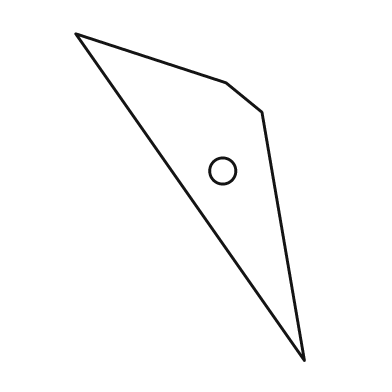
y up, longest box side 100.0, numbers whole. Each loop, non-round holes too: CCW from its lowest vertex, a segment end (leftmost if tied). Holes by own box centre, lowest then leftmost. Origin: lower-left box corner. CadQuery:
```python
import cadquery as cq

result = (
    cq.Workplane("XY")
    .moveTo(70.0, 0.0)
    .lineTo(57.0, 76.0)
    .lineTo(46.0, 85.0)
    .lineTo(0.0, 100.0)
    .close()
    .moveTo(45.0, 58.0)
    .circle(4.0)
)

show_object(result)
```